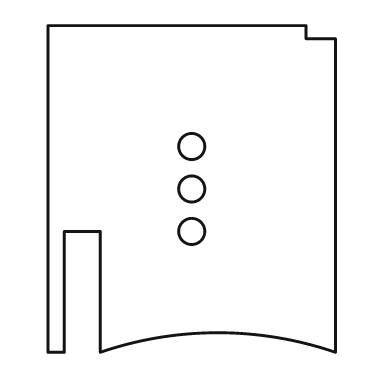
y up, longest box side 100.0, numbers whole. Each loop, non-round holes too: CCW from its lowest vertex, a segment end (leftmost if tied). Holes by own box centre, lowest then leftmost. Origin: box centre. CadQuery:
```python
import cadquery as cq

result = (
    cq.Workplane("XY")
    .moveTo(-44.0, -50.0)
    .lineTo(-39.0, -50.0)
    .lineTo(-39.0, -13.0)
    .lineTo(-28.0, -13.0)
    .lineTo(-28.0, -50.0)
    .threePointArc((8.0, -44.0), (44.0, -50.0))
    .lineTo(44.0, 46.0)
    .lineTo(35.0, 46.0)
    .lineTo(35.0, 50.0)
    .lineTo(-44.0, 50.0)
    .close()
    .moveTo(0.0, -13.0)
    .circle(4.0)
    .moveTo(0.0, 0.0)
    .circle(4.0)
    .moveTo(0.0, 13.0)
    .circle(4.0)
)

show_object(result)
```